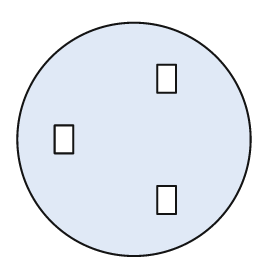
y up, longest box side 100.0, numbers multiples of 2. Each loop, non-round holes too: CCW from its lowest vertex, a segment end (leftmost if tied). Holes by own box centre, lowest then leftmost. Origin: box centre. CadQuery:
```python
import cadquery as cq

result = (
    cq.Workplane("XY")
    .moveTo(0.0, 0.0)
    .circle(50.0)
    .moveTo(10.0, -32.0)
    .lineTo(18.0, -32.0)
    .lineTo(18.0, -20.0)
    .lineTo(10.0, -20.0)
    .close()
    .moveTo(-34.0, -6.0)
    .lineTo(-26.0, -6.0)
    .lineTo(-26.0, 6.0)
    .lineTo(-34.0, 6.0)
    .close()
    .moveTo(10.0, 20.0)
    .lineTo(18.0, 20.0)
    .lineTo(18.0, 32.0)
    .lineTo(10.0, 32.0)
    .close()
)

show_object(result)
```